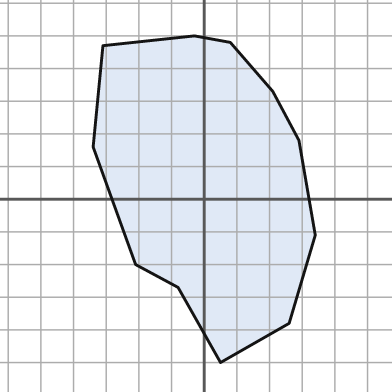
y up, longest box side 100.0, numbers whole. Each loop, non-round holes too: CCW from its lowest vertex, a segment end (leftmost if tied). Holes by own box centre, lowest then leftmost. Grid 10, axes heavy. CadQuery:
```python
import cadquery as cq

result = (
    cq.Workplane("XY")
    .moveTo(5.0, -50.0)
    .lineTo(26.0, -38.0)
    .lineTo(34.0, -11.0)
    .lineTo(29.0, 18.0)
    .lineTo(21.0, 33.0)
    .lineTo(8.0, 48.0)
    .lineTo(-3.0, 50.0)
    .lineTo(-31.0, 47.0)
    .lineTo(-34.0, 16.0)
    .lineTo(-21.0, -20.0)
    .lineTo(-8.0, -27.0)
    .close()
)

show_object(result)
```